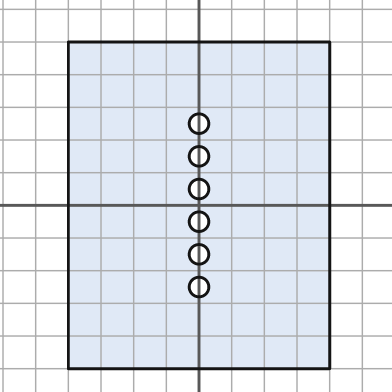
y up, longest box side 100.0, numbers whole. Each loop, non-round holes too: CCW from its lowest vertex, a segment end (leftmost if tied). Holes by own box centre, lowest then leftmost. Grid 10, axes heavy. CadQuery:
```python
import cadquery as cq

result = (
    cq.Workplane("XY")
    .moveTo(-40.0, -50.0)
    .lineTo(40.0, -50.0)
    .lineTo(40.0, 50.0)
    .lineTo(-40.0, 50.0)
    .close()
    .moveTo(0.0, -25.0)
    .circle(3.0)
    .moveTo(0.0, -15.0)
    .circle(3.0)
    .moveTo(0.0, -5.0)
    .circle(3.0)
    .moveTo(0.0, 5.0)
    .circle(3.0)
    .moveTo(0.0, 15.0)
    .circle(3.0)
    .moveTo(0.0, 25.0)
    .circle(3.0)
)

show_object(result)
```